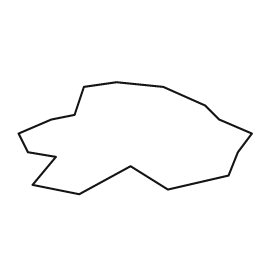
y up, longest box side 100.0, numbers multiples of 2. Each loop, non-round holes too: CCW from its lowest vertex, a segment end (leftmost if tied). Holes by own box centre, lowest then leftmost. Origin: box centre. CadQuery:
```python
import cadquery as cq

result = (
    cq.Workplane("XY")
    .moveTo(-24.0, -24.0)
    .lineTo(-2.0, -12.0)
    .lineTo(14.0, -22.0)
    .lineTo(40.0, -16.0)
    .lineTo(44.0, -6.0)
    .lineTo(50.0, 2.0)
    .lineTo(36.0, 8.0)
    .lineTo(30.0, 14.0)
    .lineTo(12.0, 22.0)
    .lineTo(-8.0, 24.0)
    .lineTo(-22.0, 22.0)
    .lineTo(-26.0, 10.0)
    .lineTo(-36.0, 8.0)
    .lineTo(-50.0, 2.0)
    .lineTo(-46.0, -6.0)
    .lineTo(-34.0, -8.0)
    .lineTo(-44.0, -20.0)
    .close()
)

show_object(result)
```